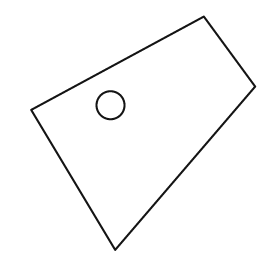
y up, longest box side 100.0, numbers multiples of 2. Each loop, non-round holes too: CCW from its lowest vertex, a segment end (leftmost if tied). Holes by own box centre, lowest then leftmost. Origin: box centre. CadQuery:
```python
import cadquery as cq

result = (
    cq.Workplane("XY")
    .moveTo(-12.0, -50.0)
    .lineTo(48.0, 20.0)
    .lineTo(26.0, 50.0)
    .lineTo(-48.0, 10.0)
    .close()
    .moveTo(-14.0, 12.0)
    .circle(6.0)
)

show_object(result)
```